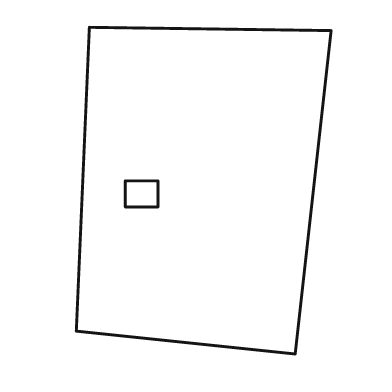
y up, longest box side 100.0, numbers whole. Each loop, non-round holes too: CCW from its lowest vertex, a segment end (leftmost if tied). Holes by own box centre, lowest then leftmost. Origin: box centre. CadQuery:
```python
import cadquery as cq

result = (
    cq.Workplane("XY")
    .moveTo(28.0, -50.0)
    .lineTo(39.0, 49.0)
    .lineTo(-35.0, 50.0)
    .lineTo(-39.0, -43.0)
    .close()
    .moveTo(-24.0, -5.0)
    .lineTo(-14.0, -5.0)
    .lineTo(-14.0, 3.0)
    .lineTo(-24.0, 3.0)
    .close()
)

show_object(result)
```